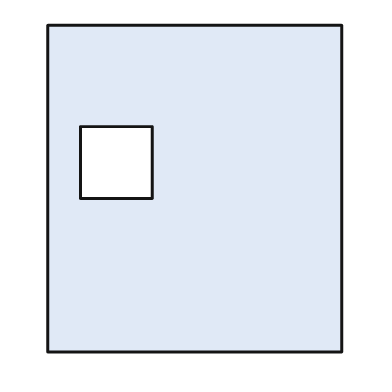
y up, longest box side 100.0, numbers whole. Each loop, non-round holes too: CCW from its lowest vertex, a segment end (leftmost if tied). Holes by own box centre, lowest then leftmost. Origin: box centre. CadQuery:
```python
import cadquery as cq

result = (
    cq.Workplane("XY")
    .moveTo(-45.0, -50.0)
    .lineTo(45.0, -50.0)
    .lineTo(45.0, 50.0)
    .lineTo(-45.0, 50.0)
    .close()
    .moveTo(-35.0, -3.0)
    .lineTo(-13.0, -3.0)
    .lineTo(-13.0, 19.0)
    .lineTo(-35.0, 19.0)
    .close()
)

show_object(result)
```